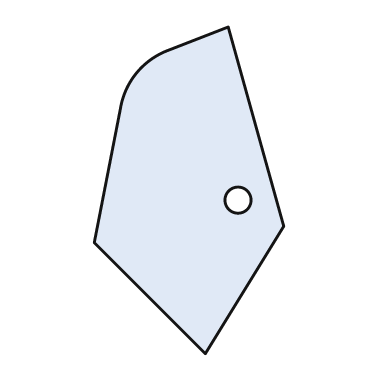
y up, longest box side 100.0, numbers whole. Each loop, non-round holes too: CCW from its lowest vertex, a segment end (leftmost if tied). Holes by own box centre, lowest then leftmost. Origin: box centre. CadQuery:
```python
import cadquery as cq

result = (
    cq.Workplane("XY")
    .moveTo(5.0, -50.0)
    .lineTo(29.0, -11.0)
    .lineTo(12.0, 50.0)
    .lineTo(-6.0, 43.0)
    .threePointArc((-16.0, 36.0), (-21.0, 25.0))
    .lineTo(-29.0, -16.0)
    .close()
    .moveTo(15.0, -3.0)
    .circle(4.0)
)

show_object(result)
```